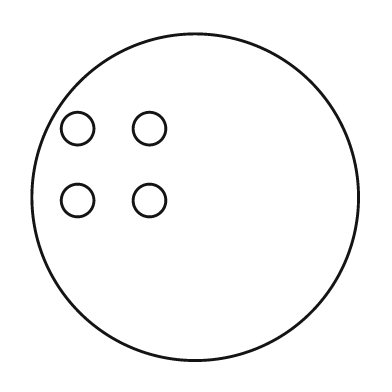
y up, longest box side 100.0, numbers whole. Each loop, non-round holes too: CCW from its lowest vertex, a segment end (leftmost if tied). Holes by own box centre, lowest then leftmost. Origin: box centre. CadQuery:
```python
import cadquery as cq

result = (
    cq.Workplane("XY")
    .moveTo(0.0, 0.0)
    .circle(50.0)
    .moveTo(-36.0, -1.0)
    .circle(5.0)
    .moveTo(-14.0, -1.0)
    .circle(5.0)
    .moveTo(-36.0, 21.0)
    .circle(5.0)
    .moveTo(-14.0, 21.0)
    .circle(5.0)
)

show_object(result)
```